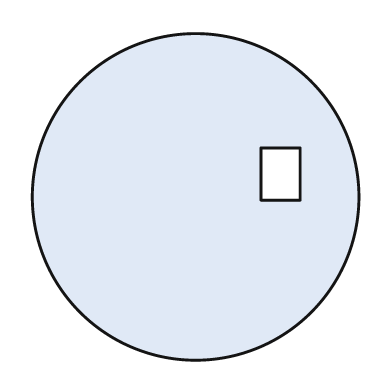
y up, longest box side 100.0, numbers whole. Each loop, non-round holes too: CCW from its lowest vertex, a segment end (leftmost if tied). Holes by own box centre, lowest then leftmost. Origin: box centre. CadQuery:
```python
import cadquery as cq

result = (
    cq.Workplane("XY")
    .moveTo(0.0, 0.0)
    .circle(50.0)
    .moveTo(20.0, -1.0)
    .lineTo(32.0, -1.0)
    .lineTo(32.0, 15.0)
    .lineTo(20.0, 15.0)
    .close()
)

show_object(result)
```